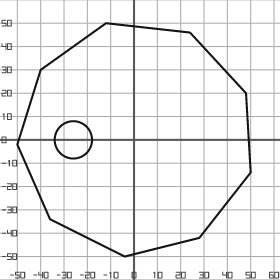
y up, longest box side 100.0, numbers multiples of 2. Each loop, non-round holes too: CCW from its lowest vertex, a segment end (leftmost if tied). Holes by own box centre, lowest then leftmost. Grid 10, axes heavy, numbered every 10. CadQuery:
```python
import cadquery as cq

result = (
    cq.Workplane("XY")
    .moveTo(-4.0, -50.0)
    .lineTo(28.0, -42.0)
    .lineTo(50.0, -14.0)
    .lineTo(48.0, 20.0)
    .lineTo(24.0, 46.0)
    .lineTo(-12.0, 50.0)
    .lineTo(-40.0, 30.0)
    .lineTo(-50.0, -2.0)
    .lineTo(-36.0, -34.0)
    .close()
    .moveTo(-26.0, 0.0)
    .circle(8.0)
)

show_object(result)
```